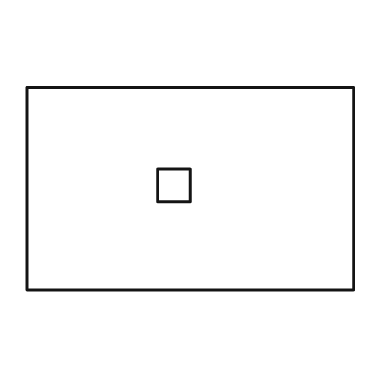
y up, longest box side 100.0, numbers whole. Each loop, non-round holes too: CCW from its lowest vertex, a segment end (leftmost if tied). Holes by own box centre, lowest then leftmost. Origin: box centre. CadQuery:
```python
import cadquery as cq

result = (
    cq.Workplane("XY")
    .moveTo(-50.0, -31.0)
    .lineTo(50.0, -31.0)
    .lineTo(50.0, 31.0)
    .lineTo(-50.0, 31.0)
    .close()
    .moveTo(-10.0, -4.0)
    .lineTo(0.0, -4.0)
    .lineTo(0.0, 6.0)
    .lineTo(-10.0, 6.0)
    .close()
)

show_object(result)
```